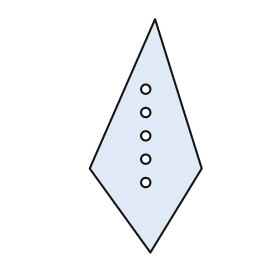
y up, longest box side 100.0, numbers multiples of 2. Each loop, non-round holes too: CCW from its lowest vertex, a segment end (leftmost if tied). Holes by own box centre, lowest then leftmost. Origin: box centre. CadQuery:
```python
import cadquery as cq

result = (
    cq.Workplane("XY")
    .moveTo(2.0, -50.0)
    .lineTo(24.0, -14.0)
    .lineTo(4.0, 50.0)
    .lineTo(-24.0, -14.0)
    .close()
    .moveTo(0.0, -20.0)
    .circle(2.0)
    .moveTo(0.0, -10.0)
    .circle(2.0)
    .moveTo(0.0, 0.0)
    .circle(2.0)
    .moveTo(0.0, 10.0)
    .circle(2.0)
    .moveTo(0.0, 20.0)
    .circle(2.0)
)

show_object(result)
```